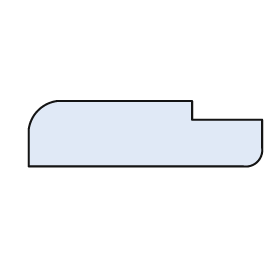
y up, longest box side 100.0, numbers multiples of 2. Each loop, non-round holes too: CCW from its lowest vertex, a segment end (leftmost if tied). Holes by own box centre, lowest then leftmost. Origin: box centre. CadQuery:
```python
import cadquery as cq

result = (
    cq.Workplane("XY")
    .moveTo(-50.0, -14.0)
    .lineTo(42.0, -14.0)
    .threePointArc((48.0, -12.0), (50.0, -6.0))
    .lineTo(50.0, 6.0)
    .lineTo(20.0, 6.0)
    .lineTo(20.0, 14.0)
    .lineTo(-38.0, 14.0)
    .threePointArc((-46.0, 10.0), (-50.0, 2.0))
    .close()
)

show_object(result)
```